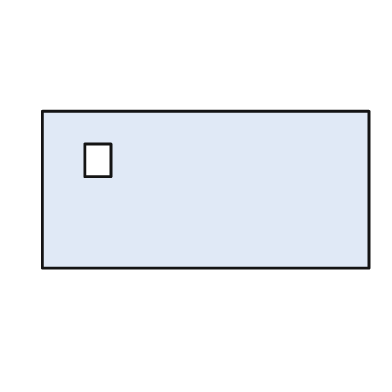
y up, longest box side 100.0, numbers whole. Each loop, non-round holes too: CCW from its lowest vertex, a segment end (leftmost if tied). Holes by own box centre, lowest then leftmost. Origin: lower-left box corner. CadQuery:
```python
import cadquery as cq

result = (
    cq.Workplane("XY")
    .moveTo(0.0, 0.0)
    .lineTo(100.0, 0.0)
    .lineTo(100.0, 48.0)
    .lineTo(0.0, 48.0)
    .close()
    .moveTo(13.0, 28.0)
    .lineTo(21.0, 28.0)
    .lineTo(21.0, 38.0)
    .lineTo(13.0, 38.0)
    .close()
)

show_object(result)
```